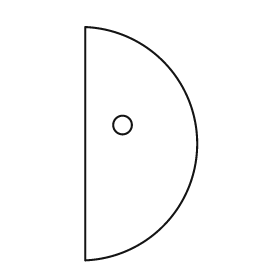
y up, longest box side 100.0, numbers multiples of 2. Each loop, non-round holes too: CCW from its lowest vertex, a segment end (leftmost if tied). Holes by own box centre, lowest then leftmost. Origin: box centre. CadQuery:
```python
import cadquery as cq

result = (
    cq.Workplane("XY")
    .moveTo(-24.0, -50.0)
    .threePointArc((24.0, 0.0), (-24.0, 50.0))
    .close()
    .moveTo(-8.0, 8.0)
    .circle(4.0)
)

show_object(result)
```